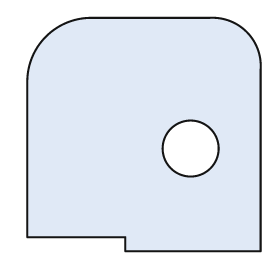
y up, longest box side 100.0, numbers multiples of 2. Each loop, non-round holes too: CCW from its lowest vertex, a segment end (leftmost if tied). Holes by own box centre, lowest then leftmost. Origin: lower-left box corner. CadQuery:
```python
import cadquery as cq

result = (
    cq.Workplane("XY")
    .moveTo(42.0, 0.0)
    .lineTo(100.0, 0.0)
    .lineTo(100.0, 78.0)
    .threePointArc((94.0, 94.0), (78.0, 100.0))
    .lineTo(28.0, 100.0)
    .threePointArc((8.0, 92.0), (0.0, 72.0))
    .lineTo(0.0, 6.0)
    .lineTo(42.0, 6.0)
    .close()
    .moveTo(70.0, 44.0)
    .circle(12.0)
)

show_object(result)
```